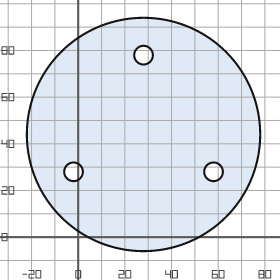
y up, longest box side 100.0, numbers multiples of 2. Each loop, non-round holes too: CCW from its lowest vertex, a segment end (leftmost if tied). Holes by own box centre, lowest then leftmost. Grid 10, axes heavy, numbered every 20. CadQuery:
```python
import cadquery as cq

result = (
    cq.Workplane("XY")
    .moveTo(28.0, 44.0)
    .circle(50.0)
    .moveTo(-2.0, 28.0)
    .circle(4.0)
    .moveTo(58.0, 28.0)
    .circle(4.0)
    .moveTo(28.0, 78.0)
    .circle(4.0)
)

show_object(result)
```